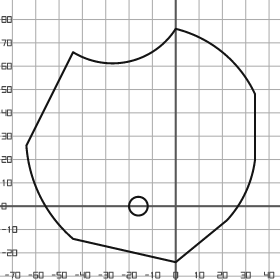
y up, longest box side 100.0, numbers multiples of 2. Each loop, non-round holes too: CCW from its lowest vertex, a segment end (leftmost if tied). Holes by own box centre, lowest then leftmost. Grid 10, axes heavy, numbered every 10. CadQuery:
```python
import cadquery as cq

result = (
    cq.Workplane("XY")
    .moveTo(0.0, -24.0)
    .lineTo(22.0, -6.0)
    .threePointArc((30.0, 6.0), (34.0, 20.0))
    .lineTo(34.0, 48.0)
    .threePointArc((20.0, 66.0), (0.0, 76.0))
    .threePointArc((-20.0, 62.0), (-44.0, 66.0))
    .lineTo(-64.0, 26.0)
    .threePointArc((-58.0, 4.0), (-44.0, -14.0))
    .close()
    .moveTo(-16.0, 0.0)
    .circle(4.0)
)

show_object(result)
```